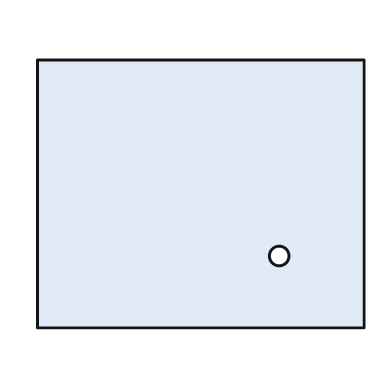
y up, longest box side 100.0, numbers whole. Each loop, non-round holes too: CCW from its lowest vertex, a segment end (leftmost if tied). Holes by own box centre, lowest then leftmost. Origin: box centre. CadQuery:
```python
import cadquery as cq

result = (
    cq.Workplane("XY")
    .moveTo(-50.0, -41.0)
    .lineTo(50.0, -41.0)
    .lineTo(50.0, 41.0)
    .lineTo(-50.0, 41.0)
    .close()
    .moveTo(24.0, -19.0)
    .circle(3.0)
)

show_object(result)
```